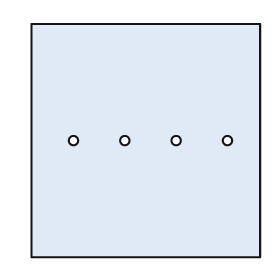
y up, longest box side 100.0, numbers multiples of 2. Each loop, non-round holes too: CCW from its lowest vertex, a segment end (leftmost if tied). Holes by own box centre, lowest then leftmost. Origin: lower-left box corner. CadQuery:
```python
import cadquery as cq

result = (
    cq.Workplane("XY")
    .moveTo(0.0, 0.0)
    .lineTo(98.0, 0.0)
    .lineTo(98.0, 100.0)
    .lineTo(0.0, 100.0)
    .close()
    .moveTo(18.0, 50.0)
    .circle(2.0)
    .moveTo(40.0, 50.0)
    .circle(2.0)
    .moveTo(62.0, 50.0)
    .circle(2.0)
    .moveTo(84.0, 50.0)
    .circle(2.0)
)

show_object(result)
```